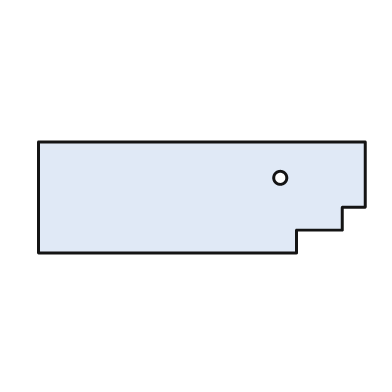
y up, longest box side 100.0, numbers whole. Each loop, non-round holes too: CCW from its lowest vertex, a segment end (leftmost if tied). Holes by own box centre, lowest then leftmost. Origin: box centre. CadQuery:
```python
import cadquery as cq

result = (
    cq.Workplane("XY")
    .moveTo(-50.0, -17.0)
    .lineTo(29.0, -17.0)
    .lineTo(29.0, -10.0)
    .lineTo(43.0, -10.0)
    .lineTo(43.0, -3.0)
    .lineTo(50.0, -3.0)
    .lineTo(50.0, 17.0)
    .lineTo(-50.0, 17.0)
    .close()
    .moveTo(24.0, 6.0)
    .circle(2.0)
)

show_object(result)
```